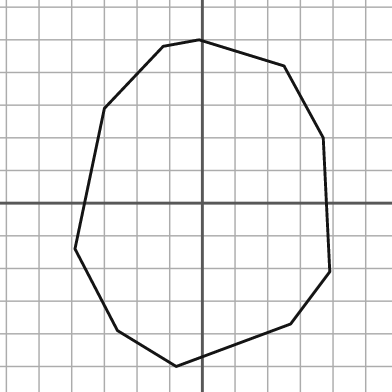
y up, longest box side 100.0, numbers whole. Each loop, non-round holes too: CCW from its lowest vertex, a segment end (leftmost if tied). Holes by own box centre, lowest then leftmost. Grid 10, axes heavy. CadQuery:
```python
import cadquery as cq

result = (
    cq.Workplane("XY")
    .moveTo(-8.0, -50.0)
    .lineTo(27.0, -37.0)
    .lineTo(39.0, -21.0)
    .lineTo(37.0, 20.0)
    .lineTo(25.0, 42.0)
    .lineTo(-1.0, 50.0)
    .lineTo(-12.0, 48.0)
    .lineTo(-30.0, 29.0)
    .lineTo(-39.0, -14.0)
    .lineTo(-26.0, -39.0)
    .close()
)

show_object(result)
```